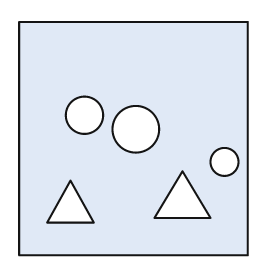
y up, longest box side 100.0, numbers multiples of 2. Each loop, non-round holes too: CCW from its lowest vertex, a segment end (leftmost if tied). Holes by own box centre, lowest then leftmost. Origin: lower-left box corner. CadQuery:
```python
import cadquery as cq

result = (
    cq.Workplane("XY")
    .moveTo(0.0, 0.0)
    .lineTo(98.0, 0.0)
    .lineTo(98.0, 100.0)
    .lineTo(0.0, 100.0)
    .close()
    .moveTo(12.0, 14.0)
    .lineTo(32.0, 14.0)
    .lineTo(22.0, 32.0)
    .close()
    .moveTo(58.0, 16.0)
    .lineTo(82.0, 16.0)
    .lineTo(70.0, 36.0)
    .close()
    .moveTo(88.0, 40.0)
    .circle(6.0)
    .moveTo(50.0, 54.0)
    .circle(10.0)
    .moveTo(28.0, 60.0)
    .circle(8.0)
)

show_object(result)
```